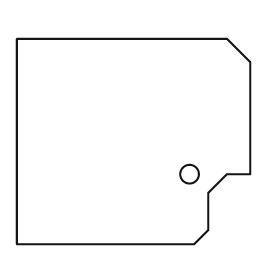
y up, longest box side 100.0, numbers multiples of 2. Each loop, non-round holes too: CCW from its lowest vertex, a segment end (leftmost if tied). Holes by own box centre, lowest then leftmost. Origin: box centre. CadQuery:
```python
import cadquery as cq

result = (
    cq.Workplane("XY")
    .moveTo(-50.0, -44.0)
    .lineTo(26.0, -44.0)
    .lineTo(32.0, -38.0)
    .lineTo(32.0, -22.0)
    .lineTo(40.0, -14.0)
    .lineTo(50.0, -14.0)
    .lineTo(50.0, 34.0)
    .lineTo(40.0, 44.0)
    .lineTo(-50.0, 44.0)
    .close()
    .moveTo(24.0, -14.0)
    .circle(4.0)
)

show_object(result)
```